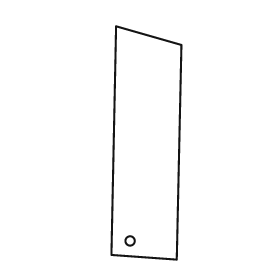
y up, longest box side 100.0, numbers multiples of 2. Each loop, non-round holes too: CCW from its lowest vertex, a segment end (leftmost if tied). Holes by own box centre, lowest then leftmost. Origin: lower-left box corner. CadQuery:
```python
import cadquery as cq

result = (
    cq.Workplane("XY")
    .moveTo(28.0, 0.0)
    .lineTo(30.0, 92.0)
    .lineTo(2.0, 100.0)
    .lineTo(0.0, 2.0)
    .close()
    .moveTo(8.0, 8.0)
    .circle(2.0)
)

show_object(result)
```